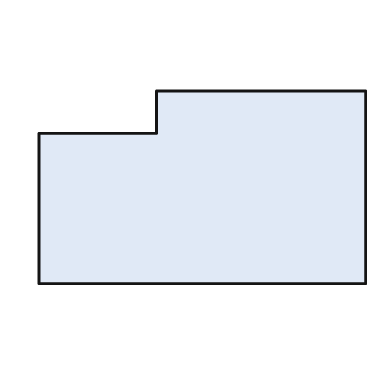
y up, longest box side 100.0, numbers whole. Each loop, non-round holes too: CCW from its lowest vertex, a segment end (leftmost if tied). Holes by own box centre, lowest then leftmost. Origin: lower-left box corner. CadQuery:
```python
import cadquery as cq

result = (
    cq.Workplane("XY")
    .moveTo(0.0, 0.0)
    .lineTo(100.0, 0.0)
    .lineTo(100.0, 59.0)
    .lineTo(36.0, 59.0)
    .lineTo(36.0, 46.0)
    .lineTo(0.0, 46.0)
    .close()
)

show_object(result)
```